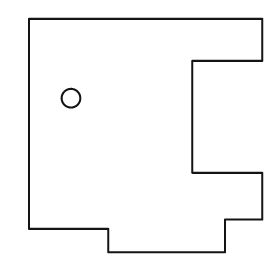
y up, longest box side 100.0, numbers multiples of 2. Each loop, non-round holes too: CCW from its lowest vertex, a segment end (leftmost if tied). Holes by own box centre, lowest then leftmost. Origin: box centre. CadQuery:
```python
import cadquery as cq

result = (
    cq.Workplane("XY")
    .moveTo(-16.0, -50.0)
    .lineTo(34.0, -50.0)
    .lineTo(34.0, -36.0)
    .lineTo(50.0, -36.0)
    .lineTo(50.0, -16.0)
    .lineTo(20.0, -16.0)
    .lineTo(20.0, 32.0)
    .lineTo(50.0, 32.0)
    .lineTo(50.0, 50.0)
    .lineTo(-50.0, 50.0)
    .lineTo(-50.0, -40.0)
    .lineTo(-16.0, -40.0)
    .close()
    .moveTo(-32.0, 16.0)
    .circle(4.0)
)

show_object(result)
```